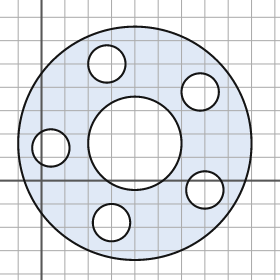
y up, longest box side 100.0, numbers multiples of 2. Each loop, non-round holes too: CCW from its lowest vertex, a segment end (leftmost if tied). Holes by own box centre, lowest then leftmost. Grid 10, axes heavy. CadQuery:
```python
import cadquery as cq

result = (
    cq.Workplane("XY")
    .moveTo(40.0, 16.0)
    .circle(50.0)
    .moveTo(30.0, -18.0)
    .circle(8.0)
    .moveTo(70.0, -4.0)
    .circle(8.0)
    .moveTo(4.0, 14.0)
    .circle(8.0)
    .moveTo(40.0, 16.0)
    .circle(20.0)
    .moveTo(68.0, 38.0)
    .circle(8.0)
    .moveTo(28.0, 50.0)
    .circle(8.0)
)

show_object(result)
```